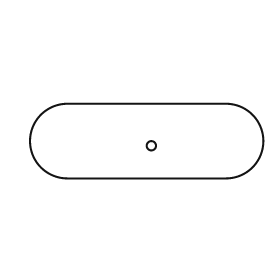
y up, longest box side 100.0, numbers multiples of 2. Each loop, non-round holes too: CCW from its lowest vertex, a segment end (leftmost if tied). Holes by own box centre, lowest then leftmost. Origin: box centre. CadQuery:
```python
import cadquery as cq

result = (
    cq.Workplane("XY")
    .moveTo(-34.0, -16.0)
    .lineTo(34.0, -16.0)
    .threePointArc((50.0, 0.0), (34.0, 16.0))
    .lineTo(-34.0, 16.0)
    .threePointArc((-50.0, 0.0), (-34.0, -16.0))
    .close()
    .moveTo(2.0, -2.0)
    .circle(2.0)
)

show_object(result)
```